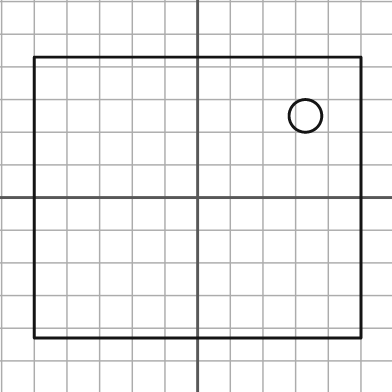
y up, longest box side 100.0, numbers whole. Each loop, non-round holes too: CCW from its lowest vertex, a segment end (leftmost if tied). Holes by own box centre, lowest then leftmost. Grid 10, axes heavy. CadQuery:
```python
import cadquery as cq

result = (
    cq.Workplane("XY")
    .moveTo(-50.0, -43.0)
    .lineTo(50.0, -43.0)
    .lineTo(50.0, 43.0)
    .lineTo(-50.0, 43.0)
    .close()
    .moveTo(33.0, 25.0)
    .circle(5.0)
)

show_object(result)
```